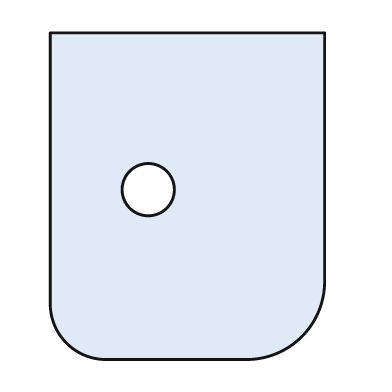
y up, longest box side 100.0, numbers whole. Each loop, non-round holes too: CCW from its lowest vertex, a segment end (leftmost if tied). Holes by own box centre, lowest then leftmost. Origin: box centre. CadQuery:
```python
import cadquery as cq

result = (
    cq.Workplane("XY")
    .moveTo(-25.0, -50.0)
    .lineTo(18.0, -50.0)
    .threePointArc((35.0, -43.0), (42.0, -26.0))
    .lineTo(42.0, 50.0)
    .lineTo(-42.0, 50.0)
    .lineTo(-42.0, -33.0)
    .threePointArc((-37.0, -45.0), (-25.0, -50.0))
    .close()
    .moveTo(-12.0, 2.0)
    .circle(8.0)
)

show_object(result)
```